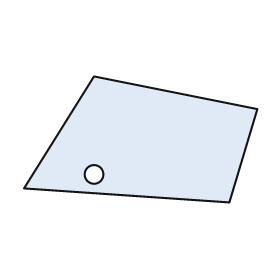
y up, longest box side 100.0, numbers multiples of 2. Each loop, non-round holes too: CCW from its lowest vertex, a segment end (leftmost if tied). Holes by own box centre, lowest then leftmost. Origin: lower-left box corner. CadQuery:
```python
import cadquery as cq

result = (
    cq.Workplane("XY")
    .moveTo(88.0, 0.0)
    .lineTo(100.0, 40.0)
    .lineTo(30.0, 54.0)
    .lineTo(0.0, 6.0)
    .close()
    .moveTo(30.0, 12.0)
    .circle(4.0)
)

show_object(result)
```